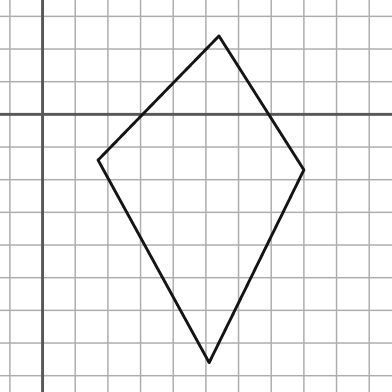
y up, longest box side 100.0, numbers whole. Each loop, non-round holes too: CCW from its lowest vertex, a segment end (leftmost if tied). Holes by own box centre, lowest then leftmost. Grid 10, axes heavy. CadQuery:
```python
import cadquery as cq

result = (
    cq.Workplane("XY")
    .moveTo(51.0, -76.0)
    .lineTo(80.0, -17.0)
    .lineTo(54.0, 24.0)
    .lineTo(17.0, -14.0)
    .close()
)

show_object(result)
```